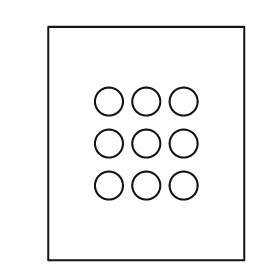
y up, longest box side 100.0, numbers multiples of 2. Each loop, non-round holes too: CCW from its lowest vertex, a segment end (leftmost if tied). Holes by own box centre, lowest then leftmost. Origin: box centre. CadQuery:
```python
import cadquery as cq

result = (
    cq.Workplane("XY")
    .moveTo(-42.0, -50.0)
    .lineTo(42.0, -50.0)
    .lineTo(42.0, 50.0)
    .lineTo(-42.0, 50.0)
    .close()
    .moveTo(-16.0, -18.0)
    .circle(6.0)
    .moveTo(0.0, -18.0)
    .circle(6.0)
    .moveTo(16.0, -18.0)
    .circle(6.0)
    .moveTo(-16.0, 0.0)
    .circle(6.0)
    .moveTo(0.0, 0.0)
    .circle(6.0)
    .moveTo(16.0, 0.0)
    .circle(6.0)
    .moveTo(-16.0, 18.0)
    .circle(6.0)
    .moveTo(0.0, 18.0)
    .circle(6.0)
    .moveTo(16.0, 18.0)
    .circle(6.0)
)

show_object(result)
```